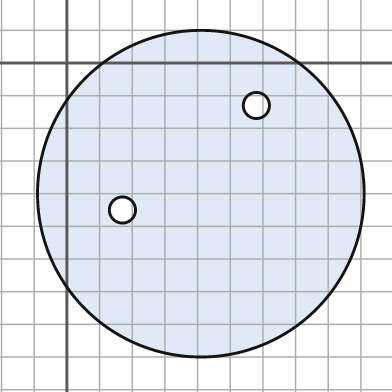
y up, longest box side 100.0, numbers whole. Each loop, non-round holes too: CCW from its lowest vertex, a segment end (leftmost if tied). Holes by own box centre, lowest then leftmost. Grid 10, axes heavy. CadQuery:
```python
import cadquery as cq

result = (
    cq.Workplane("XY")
    .moveTo(41.0, -40.0)
    .circle(50.0)
    .moveTo(17.0, -45.0)
    .circle(4.0)
    .moveTo(58.0, -13.0)
    .circle(4.0)
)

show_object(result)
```